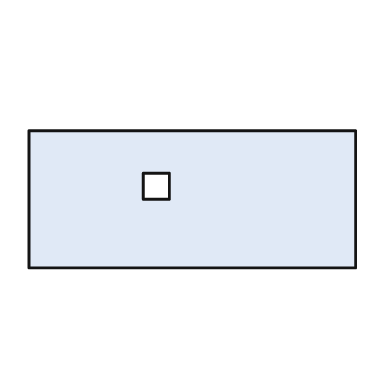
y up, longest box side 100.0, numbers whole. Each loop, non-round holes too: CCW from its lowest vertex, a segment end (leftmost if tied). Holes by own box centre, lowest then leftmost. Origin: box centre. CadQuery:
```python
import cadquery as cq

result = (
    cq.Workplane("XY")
    .moveTo(-50.0, -21.0)
    .lineTo(50.0, -21.0)
    .lineTo(50.0, 21.0)
    .lineTo(-50.0, 21.0)
    .close()
    .moveTo(-15.0, 0.0)
    .lineTo(-7.0, 0.0)
    .lineTo(-7.0, 8.0)
    .lineTo(-15.0, 8.0)
    .close()
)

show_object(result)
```